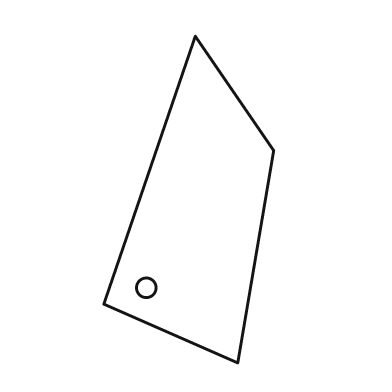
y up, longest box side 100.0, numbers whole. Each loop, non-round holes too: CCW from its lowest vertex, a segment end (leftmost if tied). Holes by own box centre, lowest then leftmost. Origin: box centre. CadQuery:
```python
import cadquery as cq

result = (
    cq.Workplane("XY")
    .moveTo(15.0, -50.0)
    .lineTo(26.0, 15.0)
    .lineTo(2.0, 50.0)
    .lineTo(-26.0, -32.0)
    .close()
    .moveTo(-13.0, -27.0)
    .circle(3.0)
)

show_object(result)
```